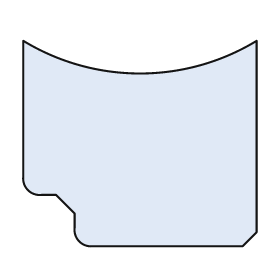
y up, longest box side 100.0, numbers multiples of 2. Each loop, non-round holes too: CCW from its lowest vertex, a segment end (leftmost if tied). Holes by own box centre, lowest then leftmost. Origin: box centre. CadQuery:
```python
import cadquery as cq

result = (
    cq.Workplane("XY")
    .moveTo(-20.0, -44.0)
    .lineTo(44.0, -44.0)
    .lineTo(50.0, -38.0)
    .lineTo(50.0, 44.0)
    .threePointArc((0.0, 30.0), (-50.0, 44.0))
    .lineTo(-50.0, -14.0)
    .threePointArc((-48.0, -20.0), (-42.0, -22.0))
    .lineTo(-36.0, -22.0)
    .lineTo(-28.0, -30.0)
    .lineTo(-28.0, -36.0)
    .threePointArc((-26.0, -42.0), (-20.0, -44.0))
    .close()
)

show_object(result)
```